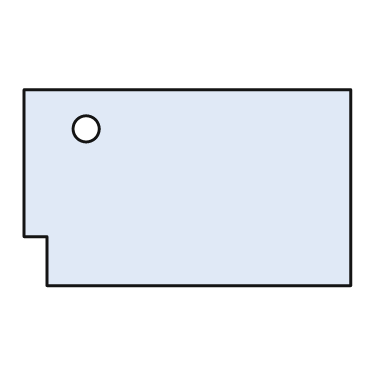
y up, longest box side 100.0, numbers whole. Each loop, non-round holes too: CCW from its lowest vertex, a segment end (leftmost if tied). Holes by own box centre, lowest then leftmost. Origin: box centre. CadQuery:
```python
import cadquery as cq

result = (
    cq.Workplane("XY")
    .moveTo(-43.0, -30.0)
    .lineTo(50.0, -30.0)
    .lineTo(50.0, 30.0)
    .lineTo(-50.0, 30.0)
    .lineTo(-50.0, -15.0)
    .lineTo(-43.0, -15.0)
    .close()
    .moveTo(-31.0, 18.0)
    .circle(4.0)
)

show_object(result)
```